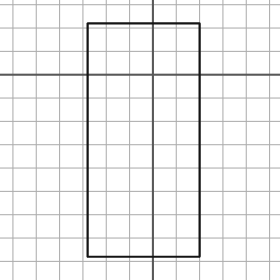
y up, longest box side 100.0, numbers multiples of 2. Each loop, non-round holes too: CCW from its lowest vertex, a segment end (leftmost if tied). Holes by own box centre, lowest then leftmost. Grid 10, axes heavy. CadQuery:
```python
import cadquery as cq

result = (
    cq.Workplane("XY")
    .moveTo(-28.0, -78.0)
    .lineTo(20.0, -78.0)
    .lineTo(20.0, 22.0)
    .lineTo(-28.0, 22.0)
    .close()
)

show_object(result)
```